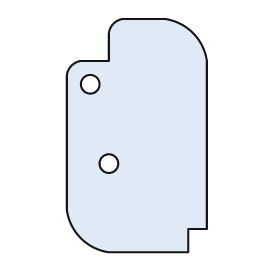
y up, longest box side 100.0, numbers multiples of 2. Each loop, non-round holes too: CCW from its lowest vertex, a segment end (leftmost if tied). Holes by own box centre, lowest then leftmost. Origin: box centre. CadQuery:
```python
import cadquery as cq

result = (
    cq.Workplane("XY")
    .moveTo(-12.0, -50.0)
    .lineTo(22.0, -50.0)
    .lineTo(22.0, -40.0)
    .lineTo(30.0, -40.0)
    .lineTo(30.0, 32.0)
    .threePointArc((24.0, 44.0), (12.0, 50.0))
    .lineTo(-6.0, 50.0)
    .threePointArc((-10.0, 48.0), (-12.0, 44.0))
    .lineTo(-12.0, 32.0)
    .lineTo(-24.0, 32.0)
    .threePointArc((-28.0, 30.0), (-30.0, 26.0))
    .lineTo(-30.0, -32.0)
    .threePointArc((-24.0, -44.0), (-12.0, -50.0))
    .close()
    .moveTo(-12.0, -12.0)
    .circle(4.0)
    .moveTo(-20.0, 22.0)
    .circle(4.0)
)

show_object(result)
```